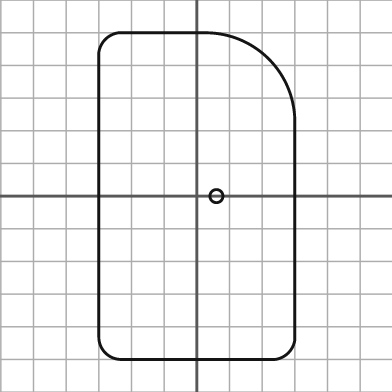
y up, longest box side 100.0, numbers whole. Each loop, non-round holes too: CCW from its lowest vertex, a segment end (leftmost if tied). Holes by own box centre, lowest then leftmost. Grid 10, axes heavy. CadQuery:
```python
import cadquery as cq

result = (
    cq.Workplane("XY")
    .moveTo(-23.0, -50.0)
    .lineTo(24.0, -50.0)
    .threePointArc((28.0, -48.0), (30.0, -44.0))
    .lineTo(30.0, 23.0)
    .threePointArc((22.0, 42.0), (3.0, 50.0))
    .lineTo(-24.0, 50.0)
    .threePointArc((-28.0, 48.0), (-30.0, 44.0))
    .lineTo(-30.0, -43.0)
    .threePointArc((-28.0, -48.0), (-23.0, -50.0))
    .close()
    .moveTo(6.0, 0.0)
    .circle(2.0)
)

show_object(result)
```